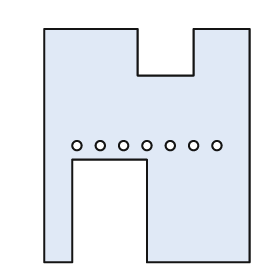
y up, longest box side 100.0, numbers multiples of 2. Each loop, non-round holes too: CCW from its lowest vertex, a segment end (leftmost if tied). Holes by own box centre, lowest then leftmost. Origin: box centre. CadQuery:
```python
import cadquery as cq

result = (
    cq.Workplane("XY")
    .moveTo(-44.0, -50.0)
    .lineTo(-32.0, -50.0)
    .lineTo(-32.0, -6.0)
    .lineTo(0.0, -6.0)
    .lineTo(0.0, -50.0)
    .lineTo(44.0, -50.0)
    .lineTo(44.0, 50.0)
    .lineTo(20.0, 50.0)
    .lineTo(20.0, 30.0)
    .lineTo(-4.0, 30.0)
    .lineTo(-4.0, 50.0)
    .lineTo(-44.0, 50.0)
    .close()
    .moveTo(-30.0, 0.0)
    .circle(2.0)
    .moveTo(-20.0, 0.0)
    .circle(2.0)
    .moveTo(-10.0, 0.0)
    .circle(2.0)
    .moveTo(0.0, 0.0)
    .circle(2.0)
    .moveTo(10.0, 0.0)
    .circle(2.0)
    .moveTo(20.0, 0.0)
    .circle(2.0)
    .moveTo(30.0, 0.0)
    .circle(2.0)
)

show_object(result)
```